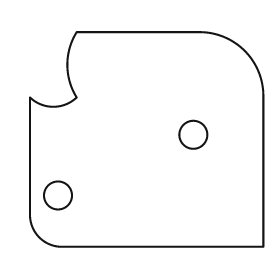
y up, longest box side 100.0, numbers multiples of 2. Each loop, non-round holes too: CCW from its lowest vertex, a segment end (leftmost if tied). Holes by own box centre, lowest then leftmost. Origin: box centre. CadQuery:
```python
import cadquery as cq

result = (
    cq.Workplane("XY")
    .moveTo(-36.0, -46.0)
    .lineTo(50.0, -46.0)
    .lineTo(50.0, 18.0)
    .threePointArc((42.0, 38.0), (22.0, 46.0))
    .lineTo(-30.0, 46.0)
    .threePointArc((-34.0, 32.0), (-30.0, 18.0))
    .threePointArc((-40.0, 14.0), (-50.0, 18.0))
    .lineTo(-50.0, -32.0)
    .threePointArc((-46.0, -42.0), (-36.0, -46.0))
    .close()
    .moveTo(-38.0, -24.0)
    .circle(6.0)
    .moveTo(20.0, 2.0)
    .circle(6.0)
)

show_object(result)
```